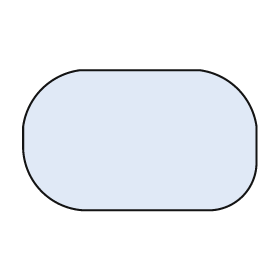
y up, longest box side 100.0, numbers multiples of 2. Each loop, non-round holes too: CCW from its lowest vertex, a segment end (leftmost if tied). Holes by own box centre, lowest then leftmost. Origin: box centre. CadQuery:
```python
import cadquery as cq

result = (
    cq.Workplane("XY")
    .moveTo(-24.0, -30.0)
    .lineTo(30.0, -30.0)
    .threePointArc((44.0, -24.0), (50.0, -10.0))
    .lineTo(50.0, 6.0)
    .threePointArc((42.0, 22.0), (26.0, 30.0))
    .lineTo(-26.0, 30.0)
    .threePointArc((-42.0, 22.0), (-50.0, 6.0))
    .lineTo(-50.0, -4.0)
    .threePointArc((-42.0, -22.0), (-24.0, -30.0))
    .close()
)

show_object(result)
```